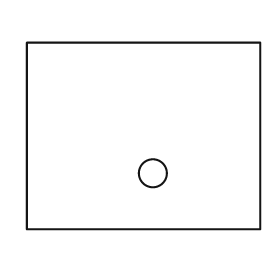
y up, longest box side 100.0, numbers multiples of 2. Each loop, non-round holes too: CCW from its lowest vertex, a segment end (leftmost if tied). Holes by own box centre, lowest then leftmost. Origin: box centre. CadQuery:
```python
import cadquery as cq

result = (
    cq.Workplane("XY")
    .moveTo(-50.0, -40.0)
    .lineTo(50.0, -40.0)
    .lineTo(50.0, 40.0)
    .lineTo(-50.0, 40.0)
    .close()
    .moveTo(4.0, -16.0)
    .circle(6.0)
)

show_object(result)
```